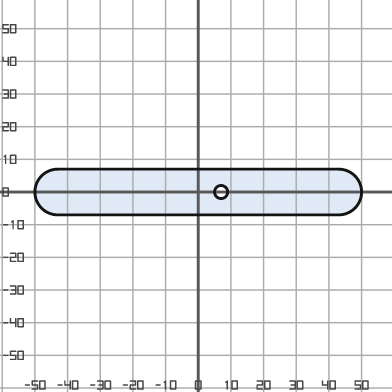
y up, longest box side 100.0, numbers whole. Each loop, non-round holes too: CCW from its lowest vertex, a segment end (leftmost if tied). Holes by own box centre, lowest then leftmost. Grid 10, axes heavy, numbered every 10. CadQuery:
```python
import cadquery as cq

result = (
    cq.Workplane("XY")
    .moveTo(-43.0, -7.0)
    .lineTo(43.0, -7.0)
    .threePointArc((50.0, 0.0), (43.0, 7.0))
    .lineTo(-43.0, 7.0)
    .threePointArc((-50.0, 0.0), (-43.0, -7.0))
    .close()
    .moveTo(7.0, 0.0)
    .circle(2.0)
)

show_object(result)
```